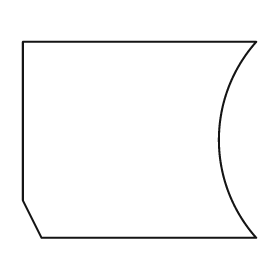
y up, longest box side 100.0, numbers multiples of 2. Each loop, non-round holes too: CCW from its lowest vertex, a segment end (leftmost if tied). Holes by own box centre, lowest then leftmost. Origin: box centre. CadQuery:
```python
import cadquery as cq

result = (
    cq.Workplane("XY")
    .moveTo(-42.0, -42.0)
    .lineTo(50.0, -42.0)
    .threePointArc((34.0, 0.0), (50.0, 42.0))
    .lineTo(-50.0, 42.0)
    .lineTo(-50.0, -26.0)
    .close()
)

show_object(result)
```